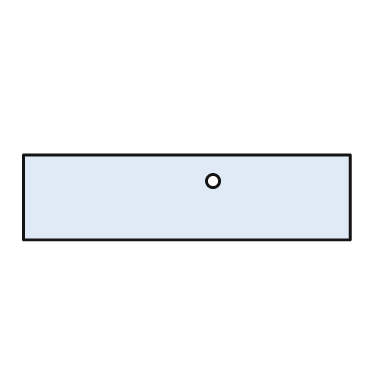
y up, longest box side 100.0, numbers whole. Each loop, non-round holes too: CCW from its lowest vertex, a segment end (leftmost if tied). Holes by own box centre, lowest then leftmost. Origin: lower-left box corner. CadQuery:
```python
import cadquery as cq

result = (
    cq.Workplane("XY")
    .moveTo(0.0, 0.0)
    .lineTo(100.0, 0.0)
    .lineTo(100.0, 26.0)
    .lineTo(0.0, 26.0)
    .close()
    .moveTo(58.0, 18.0)
    .circle(2.0)
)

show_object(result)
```